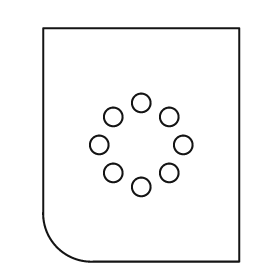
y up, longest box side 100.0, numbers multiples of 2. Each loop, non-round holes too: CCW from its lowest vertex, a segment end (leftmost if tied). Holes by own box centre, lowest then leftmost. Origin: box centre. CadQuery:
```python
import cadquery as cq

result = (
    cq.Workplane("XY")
    .moveTo(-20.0, -50.0)
    .lineTo(42.0, -50.0)
    .lineTo(42.0, 50.0)
    .lineTo(-42.0, 50.0)
    .lineTo(-42.0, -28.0)
    .threePointArc((-36.0, -44.0), (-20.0, -50.0))
    .close()
    .moveTo(0.0, -18.0)
    .circle(4.0)
    .moveTo(-12.0, -12.0)
    .circle(4.0)
    .moveTo(12.0, -12.0)
    .circle(4.0)
    .moveTo(-18.0, 0.0)
    .circle(4.0)
    .moveTo(18.0, 0.0)
    .circle(4.0)
    .moveTo(-12.0, 12.0)
    .circle(4.0)
    .moveTo(12.0, 12.0)
    .circle(4.0)
    .moveTo(0.0, 18.0)
    .circle(4.0)
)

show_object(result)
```